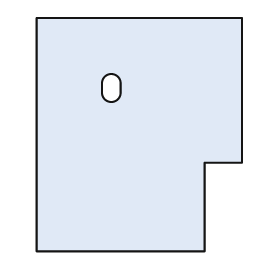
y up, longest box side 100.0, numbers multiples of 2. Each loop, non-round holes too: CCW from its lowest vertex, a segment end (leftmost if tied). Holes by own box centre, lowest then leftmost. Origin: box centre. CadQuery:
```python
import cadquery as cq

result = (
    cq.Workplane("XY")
    .moveTo(-44.0, -50.0)
    .lineTo(28.0, -50.0)
    .lineTo(28.0, -12.0)
    .lineTo(44.0, -12.0)
    .lineTo(44.0, 50.0)
    .lineTo(-44.0, 50.0)
    .close()
    .moveTo(-16.0, 18.0)
    .threePointArc((-12.0, 14.0), (-8.0, 18.0))
    .lineTo(-8.0, 22.0)
    .threePointArc((-12.0, 26.0), (-16.0, 22.0))
    .close()
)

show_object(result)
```